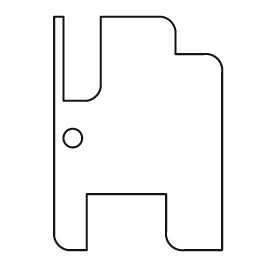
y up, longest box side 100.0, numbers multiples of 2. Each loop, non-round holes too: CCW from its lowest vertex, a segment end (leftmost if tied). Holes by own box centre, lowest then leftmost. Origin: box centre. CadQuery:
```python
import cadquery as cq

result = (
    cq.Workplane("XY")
    .moveTo(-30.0, -50.0)
    .lineTo(-22.0, -50.0)
    .lineTo(-22.0, -26.0)
    .lineTo(12.0, -26.0)
    .lineTo(12.0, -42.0)
    .threePointArc((14.0, -48.0), (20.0, -50.0))
    .lineTo(36.0, -50.0)
    .lineTo(36.0, 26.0)
    .threePointArc((34.0, 32.0), (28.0, 34.0))
    .lineTo(16.0, 34.0)
    .lineTo(16.0, 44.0)
    .threePointArc((14.0, 48.0), (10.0, 50.0))
    .lineTo(-16.0, 50.0)
    .lineTo(-16.0, 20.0)
    .threePointArc((-18.0, 16.0), (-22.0, 14.0))
    .lineTo(-32.0, 14.0)
    .lineTo(-32.0, 50.0)
    .lineTo(-36.0, 50.0)
    .lineTo(-36.0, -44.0)
    .threePointArc((-34.0, -48.0), (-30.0, -50.0))
    .close()
    .moveTo(-28.0, -2.0)
    .circle(4.0)
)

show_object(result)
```